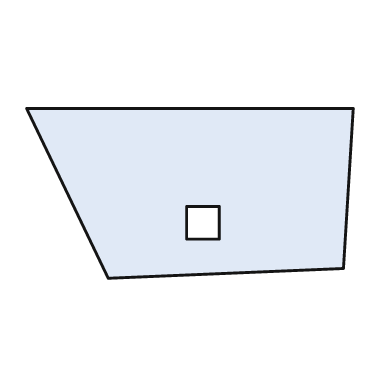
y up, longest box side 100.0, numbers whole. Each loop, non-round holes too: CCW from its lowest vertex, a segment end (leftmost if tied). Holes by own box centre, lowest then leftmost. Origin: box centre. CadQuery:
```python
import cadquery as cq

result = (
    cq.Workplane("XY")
    .moveTo(-25.0, -26.0)
    .lineTo(47.0, -23.0)
    .lineTo(50.0, 26.0)
    .lineTo(-50.0, 26.0)
    .close()
    .moveTo(-1.0, -14.0)
    .lineTo(9.0, -14.0)
    .lineTo(9.0, -4.0)
    .lineTo(-1.0, -4.0)
    .close()
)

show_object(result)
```